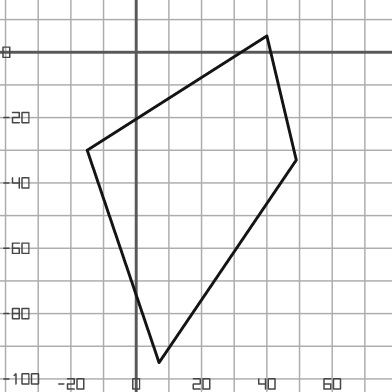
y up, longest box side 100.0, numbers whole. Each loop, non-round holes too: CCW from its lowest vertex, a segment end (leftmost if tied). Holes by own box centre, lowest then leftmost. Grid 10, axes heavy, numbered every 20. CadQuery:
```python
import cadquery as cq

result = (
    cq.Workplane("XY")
    .moveTo(7.0, -95.0)
    .lineTo(49.0, -33.0)
    .lineTo(40.0, 5.0)
    .lineTo(-15.0, -30.0)
    .close()
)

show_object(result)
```